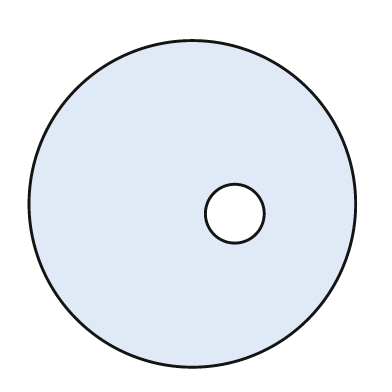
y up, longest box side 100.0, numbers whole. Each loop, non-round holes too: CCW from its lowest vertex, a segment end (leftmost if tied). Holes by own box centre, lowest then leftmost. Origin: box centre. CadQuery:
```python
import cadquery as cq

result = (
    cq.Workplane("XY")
    .moveTo(0.0, 0.0)
    .circle(50.0)
    .moveTo(13.0, -3.0)
    .circle(9.0)
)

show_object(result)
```